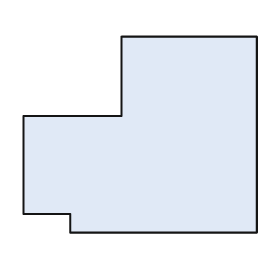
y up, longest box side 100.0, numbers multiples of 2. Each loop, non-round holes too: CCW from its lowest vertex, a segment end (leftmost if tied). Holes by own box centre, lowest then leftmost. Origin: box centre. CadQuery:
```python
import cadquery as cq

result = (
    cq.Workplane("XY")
    .moveTo(-30.0, -42.0)
    .lineTo(50.0, -42.0)
    .lineTo(50.0, 42.0)
    .lineTo(-8.0, 42.0)
    .lineTo(-8.0, 8.0)
    .lineTo(-50.0, 8.0)
    .lineTo(-50.0, -34.0)
    .lineTo(-30.0, -34.0)
    .close()
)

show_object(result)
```